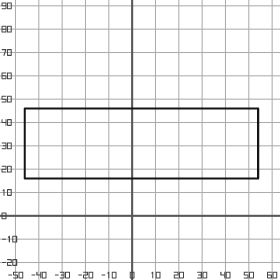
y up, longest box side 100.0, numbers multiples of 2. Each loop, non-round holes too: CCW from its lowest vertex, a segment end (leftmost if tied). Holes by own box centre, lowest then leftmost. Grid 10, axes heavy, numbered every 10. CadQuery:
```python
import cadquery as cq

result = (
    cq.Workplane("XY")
    .moveTo(-46.0, 16.0)
    .lineTo(54.0, 16.0)
    .lineTo(54.0, 46.0)
    .lineTo(-46.0, 46.0)
    .close()
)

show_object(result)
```